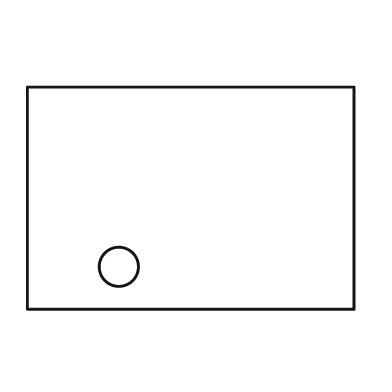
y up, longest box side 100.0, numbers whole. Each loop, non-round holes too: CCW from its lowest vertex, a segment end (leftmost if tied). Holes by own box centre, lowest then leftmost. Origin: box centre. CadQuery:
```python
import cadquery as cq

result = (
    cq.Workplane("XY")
    .moveTo(-50.0, -34.0)
    .lineTo(50.0, -34.0)
    .lineTo(50.0, 34.0)
    .lineTo(-50.0, 34.0)
    .close()
    .moveTo(-22.0, -21.0)
    .circle(6.0)
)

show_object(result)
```